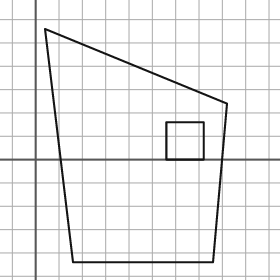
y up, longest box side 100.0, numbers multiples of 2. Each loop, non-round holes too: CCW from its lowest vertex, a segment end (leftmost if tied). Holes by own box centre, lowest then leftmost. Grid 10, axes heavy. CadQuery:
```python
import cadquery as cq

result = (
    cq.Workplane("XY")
    .moveTo(16.0, -44.0)
    .lineTo(76.0, -44.0)
    .lineTo(82.0, 24.0)
    .lineTo(4.0, 56.0)
    .close()
    .moveTo(56.0, 0.0)
    .lineTo(72.0, 0.0)
    .lineTo(72.0, 16.0)
    .lineTo(56.0, 16.0)
    .close()
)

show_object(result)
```